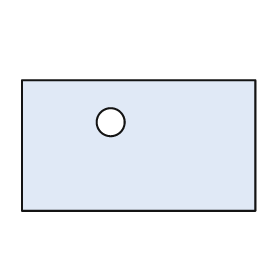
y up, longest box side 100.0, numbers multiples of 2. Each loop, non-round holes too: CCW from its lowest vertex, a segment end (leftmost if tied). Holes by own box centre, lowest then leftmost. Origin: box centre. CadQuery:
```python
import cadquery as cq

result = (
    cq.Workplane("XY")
    .moveTo(-50.0, -28.0)
    .lineTo(50.0, -28.0)
    .lineTo(50.0, 28.0)
    .lineTo(-50.0, 28.0)
    .close()
    .moveTo(-12.0, 10.0)
    .circle(6.0)
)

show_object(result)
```